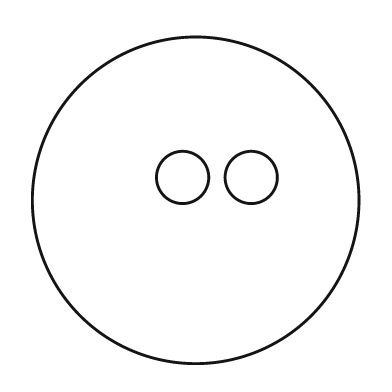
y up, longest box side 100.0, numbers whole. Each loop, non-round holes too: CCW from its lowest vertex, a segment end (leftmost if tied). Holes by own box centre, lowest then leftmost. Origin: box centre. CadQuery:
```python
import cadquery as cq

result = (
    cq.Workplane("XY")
    .moveTo(0.0, 0.0)
    .circle(50.0)
    .moveTo(-4.0, 7.0)
    .circle(8.0)
    .moveTo(17.0, 7.0)
    .circle(8.0)
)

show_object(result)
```